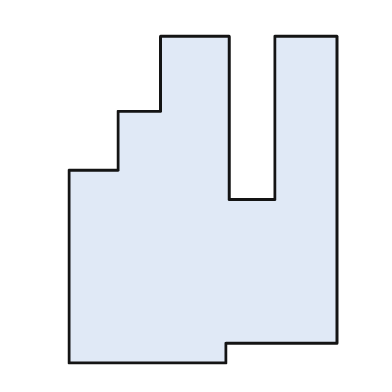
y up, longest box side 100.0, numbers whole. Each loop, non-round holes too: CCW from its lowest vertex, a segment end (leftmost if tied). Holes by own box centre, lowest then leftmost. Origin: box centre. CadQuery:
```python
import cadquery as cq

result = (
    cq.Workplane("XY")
    .moveTo(-41.0, -50.0)
    .lineTo(7.0, -50.0)
    .lineTo(7.0, -44.0)
    .lineTo(41.0, -44.0)
    .lineTo(41.0, 50.0)
    .lineTo(22.0, 50.0)
    .lineTo(22.0, 0.0)
    .lineTo(8.0, 0.0)
    .lineTo(8.0, 50.0)
    .lineTo(-13.0, 50.0)
    .lineTo(-13.0, 27.0)
    .lineTo(-26.0, 27.0)
    .lineTo(-26.0, 9.0)
    .lineTo(-41.0, 9.0)
    .close()
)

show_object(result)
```